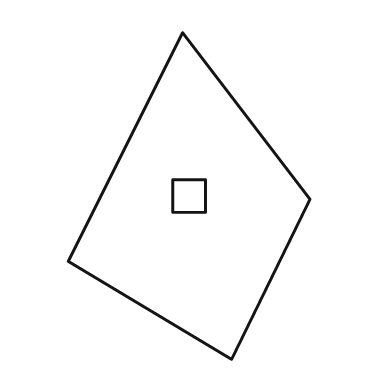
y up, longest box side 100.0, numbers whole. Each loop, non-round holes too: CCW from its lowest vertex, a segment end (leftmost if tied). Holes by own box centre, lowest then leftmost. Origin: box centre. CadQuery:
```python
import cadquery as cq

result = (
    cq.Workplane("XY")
    .moveTo(13.0, -50.0)
    .lineTo(37.0, -1.0)
    .lineTo(-2.0, 50.0)
    .lineTo(-37.0, -20.0)
    .close()
    .moveTo(-5.0, -5.0)
    .lineTo(5.0, -5.0)
    .lineTo(5.0, 5.0)
    .lineTo(-5.0, 5.0)
    .close()
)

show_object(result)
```